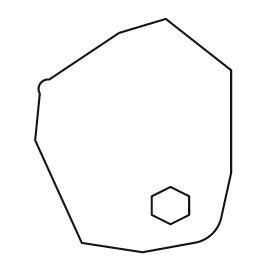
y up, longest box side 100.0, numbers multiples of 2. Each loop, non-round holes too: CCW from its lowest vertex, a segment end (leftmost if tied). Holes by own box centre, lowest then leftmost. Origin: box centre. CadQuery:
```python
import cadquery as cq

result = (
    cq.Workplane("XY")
    .moveTo(4.0, -50.0)
    .lineTo(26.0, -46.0)
    .threePointArc((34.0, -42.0), (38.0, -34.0))
    .lineTo(42.0, -16.0)
    .lineTo(42.0, 28.0)
    .lineTo(14.0, 50.0)
    .lineTo(-6.0, 44.0)
    .lineTo(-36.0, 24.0)
    .threePointArc((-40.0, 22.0), (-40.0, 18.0))
    .lineTo(-42.0, -2.0)
    .lineTo(-22.0, -46.0)
    .close()
    .moveTo(16.0, -38.0)
    .lineTo(24.0, -34.0)
    .lineTo(24.0, -26.0)
    .lineTo(16.0, -22.0)
    .lineTo(8.0, -26.0)
    .lineTo(8.0, -34.0)
    .close()
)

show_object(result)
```